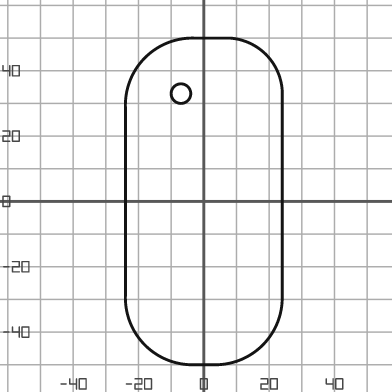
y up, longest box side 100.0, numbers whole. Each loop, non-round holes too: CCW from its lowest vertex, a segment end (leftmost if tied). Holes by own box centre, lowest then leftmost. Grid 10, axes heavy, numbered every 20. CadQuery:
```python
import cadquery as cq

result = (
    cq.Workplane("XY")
    .moveTo(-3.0, -50.0)
    .lineTo(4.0, -50.0)
    .threePointArc((18.0, -44.0), (24.0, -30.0))
    .lineTo(24.0, 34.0)
    .threePointArc((19.0, 45.0), (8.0, 50.0))
    .lineTo(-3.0, 50.0)
    .threePointArc((-18.0, 44.0), (-24.0, 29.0))
    .lineTo(-24.0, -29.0)
    .threePointArc((-18.0, -44.0), (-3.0, -50.0))
    .close()
    .moveTo(-7.0, 33.0)
    .circle(3.0)
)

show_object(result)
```